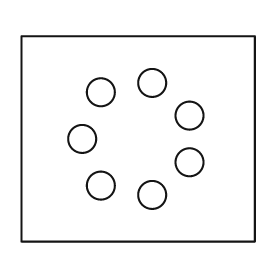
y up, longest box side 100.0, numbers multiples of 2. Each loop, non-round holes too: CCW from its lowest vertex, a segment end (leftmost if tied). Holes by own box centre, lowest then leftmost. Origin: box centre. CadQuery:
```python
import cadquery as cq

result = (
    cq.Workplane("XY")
    .moveTo(-50.0, -44.0)
    .lineTo(50.0, -44.0)
    .lineTo(50.0, 44.0)
    .lineTo(-50.0, 44.0)
    .close()
    .moveTo(6.0, -24.0)
    .circle(6.0)
    .moveTo(-16.0, -20.0)
    .circle(6.0)
    .moveTo(22.0, -10.0)
    .circle(6.0)
    .moveTo(-24.0, 0.0)
    .circle(6.0)
    .moveTo(22.0, 10.0)
    .circle(6.0)
    .moveTo(-16.0, 20.0)
    .circle(6.0)
    .moveTo(6.0, 24.0)
    .circle(6.0)
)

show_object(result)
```